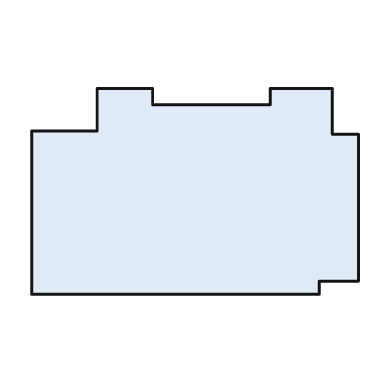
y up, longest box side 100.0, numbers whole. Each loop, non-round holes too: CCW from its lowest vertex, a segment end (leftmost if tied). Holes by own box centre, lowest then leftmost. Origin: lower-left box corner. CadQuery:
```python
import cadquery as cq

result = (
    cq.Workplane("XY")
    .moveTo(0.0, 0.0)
    .lineTo(88.0, 0.0)
    .lineTo(88.0, 4.0)
    .lineTo(100.0, 4.0)
    .lineTo(100.0, 49.0)
    .lineTo(92.0, 49.0)
    .lineTo(92.0, 63.0)
    .lineTo(73.0, 63.0)
    .lineTo(73.0, 58.0)
    .lineTo(37.0, 58.0)
    .lineTo(37.0, 63.0)
    .lineTo(20.0, 63.0)
    .lineTo(20.0, 50.0)
    .lineTo(0.0, 50.0)
    .close()
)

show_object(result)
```